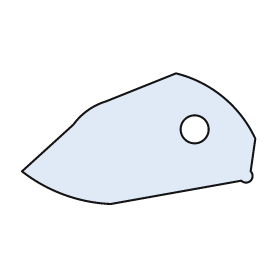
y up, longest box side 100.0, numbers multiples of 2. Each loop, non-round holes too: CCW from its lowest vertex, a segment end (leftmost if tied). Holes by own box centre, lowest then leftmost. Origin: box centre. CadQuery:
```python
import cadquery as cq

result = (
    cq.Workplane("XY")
    .moveTo(-12.0, -28.0)
    .lineTo(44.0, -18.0)
    .threePointArc((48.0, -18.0), (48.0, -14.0))
    .lineTo(50.0, 0.0)
    .threePointArc((36.0, 18.0), (16.0, 28.0))
    .lineTo(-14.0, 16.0)
    .threePointArc((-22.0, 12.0), (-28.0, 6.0))
    .lineTo(-50.0, -14.0)
    .threePointArc((-32.0, -24.0), (-12.0, -28.0))
    .close()
    .moveTo(24.0, 4.0)
    .circle(6.0)
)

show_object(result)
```